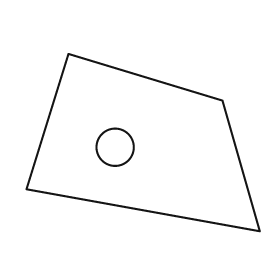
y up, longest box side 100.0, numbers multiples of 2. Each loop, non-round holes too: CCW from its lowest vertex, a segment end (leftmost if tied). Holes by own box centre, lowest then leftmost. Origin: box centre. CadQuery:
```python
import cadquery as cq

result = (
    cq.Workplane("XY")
    .moveTo(50.0, -38.0)
    .lineTo(34.0, 18.0)
    .lineTo(-32.0, 38.0)
    .lineTo(-50.0, -20.0)
    .close()
    .moveTo(-12.0, -2.0)
    .circle(8.0)
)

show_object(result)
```